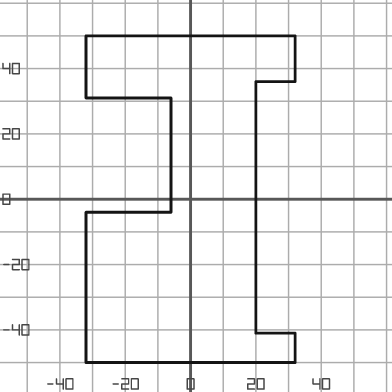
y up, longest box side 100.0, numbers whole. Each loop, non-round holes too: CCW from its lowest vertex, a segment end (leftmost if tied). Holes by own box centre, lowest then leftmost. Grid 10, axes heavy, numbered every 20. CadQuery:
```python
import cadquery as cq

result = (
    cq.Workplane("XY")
    .moveTo(-32.0, -50.0)
    .lineTo(32.0, -50.0)
    .lineTo(32.0, -41.0)
    .lineTo(20.0, -41.0)
    .lineTo(20.0, 36.0)
    .lineTo(32.0, 36.0)
    .lineTo(32.0, 50.0)
    .lineTo(-32.0, 50.0)
    .lineTo(-32.0, 31.0)
    .lineTo(-6.0, 31.0)
    .lineTo(-6.0, -4.0)
    .lineTo(-32.0, -4.0)
    .close()
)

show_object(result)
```